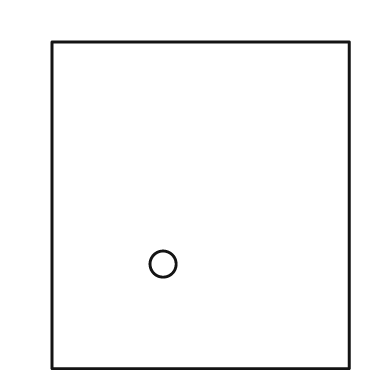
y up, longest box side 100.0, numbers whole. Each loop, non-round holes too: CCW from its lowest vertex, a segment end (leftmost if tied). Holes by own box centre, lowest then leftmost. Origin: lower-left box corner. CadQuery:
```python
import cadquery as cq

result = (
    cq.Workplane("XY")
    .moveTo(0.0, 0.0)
    .lineTo(91.0, 0.0)
    .lineTo(91.0, 100.0)
    .lineTo(0.0, 100.0)
    .close()
    .moveTo(34.0, 32.0)
    .circle(4.0)
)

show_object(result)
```